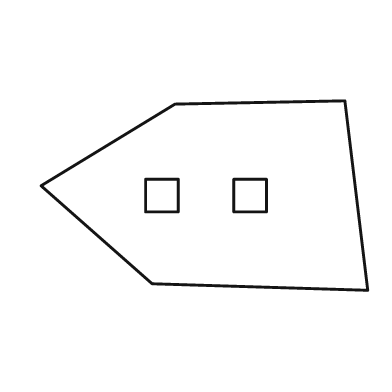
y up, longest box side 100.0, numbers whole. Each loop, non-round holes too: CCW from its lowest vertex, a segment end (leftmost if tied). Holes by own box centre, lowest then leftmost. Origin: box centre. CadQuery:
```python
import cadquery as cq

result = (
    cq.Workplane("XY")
    .moveTo(50.0, -29.0)
    .lineTo(43.0, 29.0)
    .lineTo(-9.0, 28.0)
    .lineTo(-50.0, 3.0)
    .lineTo(-16.0, -27.0)
    .close()
    .moveTo(-18.0, -5.0)
    .lineTo(-8.0, -5.0)
    .lineTo(-8.0, 5.0)
    .lineTo(-18.0, 5.0)
    .close()
    .moveTo(9.0, -5.0)
    .lineTo(19.0, -5.0)
    .lineTo(19.0, 5.0)
    .lineTo(9.0, 5.0)
    .close()
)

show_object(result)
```